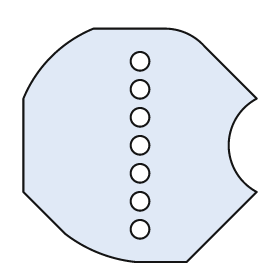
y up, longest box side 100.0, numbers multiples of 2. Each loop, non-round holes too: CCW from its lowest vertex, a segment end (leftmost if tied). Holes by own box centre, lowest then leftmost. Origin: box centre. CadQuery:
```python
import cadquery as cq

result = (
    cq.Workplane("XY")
    .moveTo(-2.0, -50.0)
    .lineTo(20.0, -50.0)
    .lineTo(50.0, -20.0)
    .threePointArc((38.0, 0.0), (50.0, 20.0))
    .lineTo(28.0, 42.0)
    .threePointArc((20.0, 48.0), (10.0, 50.0))
    .lineTo(-20.0, 50.0)
    .threePointArc((-38.0, 38.0), (-50.0, 20.0))
    .lineTo(-50.0, -20.0)
    .lineTo(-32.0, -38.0)
    .threePointArc((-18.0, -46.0), (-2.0, -50.0))
    .close()
    .moveTo(0.0, -36.0)
    .circle(4.0)
    .moveTo(0.0, -24.0)
    .circle(4.0)
    .moveTo(0.0, -12.0)
    .circle(4.0)
    .moveTo(0.0, 0.0)
    .circle(4.0)
    .moveTo(0.0, 12.0)
    .circle(4.0)
    .moveTo(0.0, 24.0)
    .circle(4.0)
    .moveTo(0.0, 36.0)
    .circle(4.0)
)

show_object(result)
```